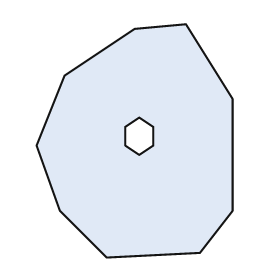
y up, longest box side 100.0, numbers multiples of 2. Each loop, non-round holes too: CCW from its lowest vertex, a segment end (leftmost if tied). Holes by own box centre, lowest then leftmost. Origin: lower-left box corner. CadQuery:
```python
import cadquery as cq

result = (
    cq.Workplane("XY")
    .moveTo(30.0, 0.0)
    .lineTo(70.0, 2.0)
    .lineTo(84.0, 20.0)
    .lineTo(84.0, 68.0)
    .lineTo(64.0, 100.0)
    .lineTo(42.0, 98.0)
    .lineTo(12.0, 78.0)
    .lineTo(0.0, 48.0)
    .lineTo(10.0, 20.0)
    .close()
    .moveTo(44.0, 44.0)
    .lineTo(50.0, 48.0)
    .lineTo(50.0, 56.0)
    .lineTo(44.0, 60.0)
    .lineTo(38.0, 56.0)
    .lineTo(38.0, 48.0)
    .close()
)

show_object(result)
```